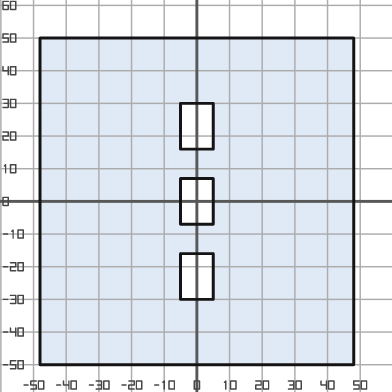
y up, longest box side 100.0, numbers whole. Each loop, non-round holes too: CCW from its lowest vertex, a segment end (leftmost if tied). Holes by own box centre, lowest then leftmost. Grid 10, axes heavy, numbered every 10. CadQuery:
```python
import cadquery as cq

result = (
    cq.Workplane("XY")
    .moveTo(-48.0, -50.0)
    .lineTo(48.0, -50.0)
    .lineTo(48.0, 50.0)
    .lineTo(-48.0, 50.0)
    .close()
    .moveTo(-5.0, -30.0)
    .lineTo(5.0, -30.0)
    .lineTo(5.0, -16.0)
    .lineTo(-5.0, -16.0)
    .close()
    .moveTo(-5.0, -7.0)
    .lineTo(5.0, -7.0)
    .lineTo(5.0, 7.0)
    .lineTo(-5.0, 7.0)
    .close()
    .moveTo(-5.0, 16.0)
    .lineTo(5.0, 16.0)
    .lineTo(5.0, 30.0)
    .lineTo(-5.0, 30.0)
    .close()
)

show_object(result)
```